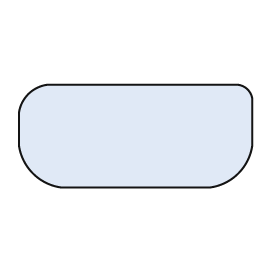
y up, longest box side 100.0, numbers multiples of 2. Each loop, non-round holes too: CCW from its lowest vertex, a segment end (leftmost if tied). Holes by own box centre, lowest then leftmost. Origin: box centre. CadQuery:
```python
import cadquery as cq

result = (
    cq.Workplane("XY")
    .moveTo(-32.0, -22.0)
    .lineTo(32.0, -22.0)
    .threePointArc((44.0, -16.0), (50.0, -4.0))
    .lineTo(50.0, 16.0)
    .threePointArc((48.0, 20.0), (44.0, 22.0))
    .lineTo(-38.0, 22.0)
    .threePointArc((-46.0, 18.0), (-50.0, 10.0))
    .lineTo(-50.0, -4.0)
    .threePointArc((-44.0, -16.0), (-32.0, -22.0))
    .close()
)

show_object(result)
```